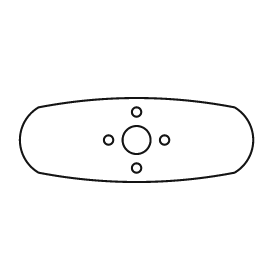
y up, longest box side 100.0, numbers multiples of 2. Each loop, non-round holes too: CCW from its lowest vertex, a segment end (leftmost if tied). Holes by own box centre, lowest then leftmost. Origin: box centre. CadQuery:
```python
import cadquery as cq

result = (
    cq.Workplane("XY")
    .moveTo(-42.0, -14.0)
    .threePointArc((0.0, -18.0), (42.0, -14.0))
    .threePointArc((50.0, 0.0), (42.0, 14.0))
    .threePointArc((0.0, 18.0), (-42.0, 14.0))
    .threePointArc((-50.0, 0.0), (-42.0, -14.0))
    .close()
    .moveTo(0.0, -12.0)
    .circle(2.0)
    .moveTo(-12.0, 0.0)
    .circle(2.0)
    .moveTo(0.0, 0.0)
    .circle(6.0)
    .moveTo(12.0, 0.0)
    .circle(2.0)
    .moveTo(0.0, 12.0)
    .circle(2.0)
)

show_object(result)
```